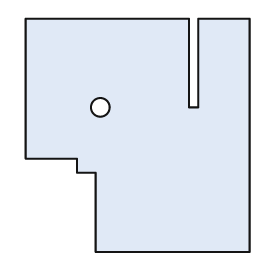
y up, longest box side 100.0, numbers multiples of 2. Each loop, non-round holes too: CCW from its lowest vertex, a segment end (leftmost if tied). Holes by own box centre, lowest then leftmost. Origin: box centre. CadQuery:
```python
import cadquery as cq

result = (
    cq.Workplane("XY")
    .moveTo(-18.0, -50.0)
    .lineTo(48.0, -50.0)
    .lineTo(48.0, 50.0)
    .lineTo(26.0, 50.0)
    .lineTo(26.0, 12.0)
    .lineTo(22.0, 12.0)
    .lineTo(22.0, 50.0)
    .lineTo(-48.0, 50.0)
    .lineTo(-48.0, -10.0)
    .lineTo(-26.0, -10.0)
    .lineTo(-26.0, -16.0)
    .lineTo(-18.0, -16.0)
    .close()
    .moveTo(-16.0, 12.0)
    .circle(4.0)
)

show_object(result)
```